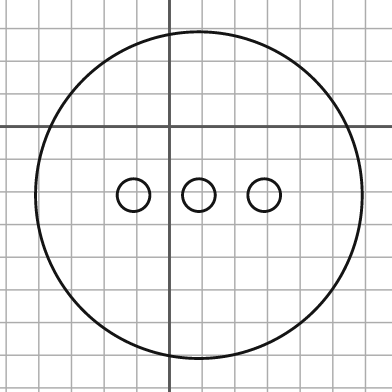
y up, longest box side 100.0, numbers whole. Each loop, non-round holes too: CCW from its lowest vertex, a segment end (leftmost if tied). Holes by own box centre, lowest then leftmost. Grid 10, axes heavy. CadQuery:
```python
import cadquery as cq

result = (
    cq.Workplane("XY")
    .moveTo(9.0, -21.0)
    .circle(50.0)
    .moveTo(-11.0, -21.0)
    .circle(5.0)
    .moveTo(9.0, -21.0)
    .circle(5.0)
    .moveTo(29.0, -21.0)
    .circle(5.0)
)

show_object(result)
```